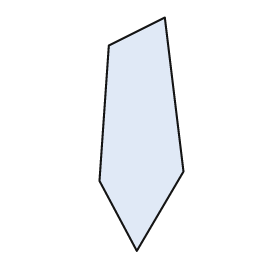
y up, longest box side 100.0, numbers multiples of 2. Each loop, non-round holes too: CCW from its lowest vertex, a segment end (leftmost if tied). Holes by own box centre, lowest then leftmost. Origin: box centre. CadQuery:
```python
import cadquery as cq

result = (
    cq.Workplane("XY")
    .moveTo(-2.0, -50.0)
    .lineTo(18.0, -16.0)
    .lineTo(10.0, 50.0)
    .lineTo(-14.0, 38.0)
    .lineTo(-18.0, -20.0)
    .close()
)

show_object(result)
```